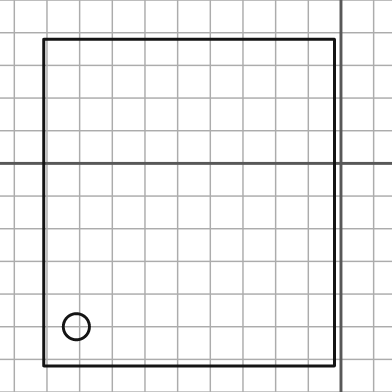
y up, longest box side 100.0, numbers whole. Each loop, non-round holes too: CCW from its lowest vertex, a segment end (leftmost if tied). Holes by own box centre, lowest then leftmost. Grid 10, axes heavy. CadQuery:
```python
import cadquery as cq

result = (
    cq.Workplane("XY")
    .moveTo(-91.0, -62.0)
    .lineTo(-2.0, -62.0)
    .lineTo(-2.0, 38.0)
    .lineTo(-91.0, 38.0)
    .close()
    .moveTo(-81.0, -50.0)
    .circle(4.0)
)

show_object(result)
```